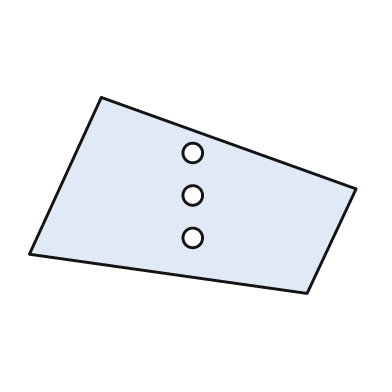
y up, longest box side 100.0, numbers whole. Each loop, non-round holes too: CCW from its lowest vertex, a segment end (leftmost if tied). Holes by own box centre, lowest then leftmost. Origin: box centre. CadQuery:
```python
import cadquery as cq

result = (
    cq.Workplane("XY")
    .moveTo(35.0, -30.0)
    .lineTo(50.0, 2.0)
    .lineTo(-28.0, 30.0)
    .lineTo(-50.0, -18.0)
    .close()
    .moveTo(0.0, -13.0)
    .circle(3.0)
    .moveTo(0.0, 0.0)
    .circle(3.0)
    .moveTo(0.0, 13.0)
    .circle(3.0)
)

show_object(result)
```